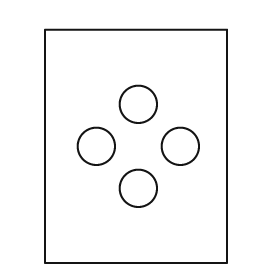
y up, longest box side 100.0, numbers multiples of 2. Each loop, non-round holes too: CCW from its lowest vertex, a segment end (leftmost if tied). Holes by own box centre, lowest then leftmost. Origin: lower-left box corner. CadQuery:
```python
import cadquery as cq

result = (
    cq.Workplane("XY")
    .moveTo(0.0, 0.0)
    .lineTo(78.0, 0.0)
    .lineTo(78.0, 100.0)
    .lineTo(0.0, 100.0)
    .close()
    .moveTo(40.0, 32.0)
    .circle(8.0)
    .moveTo(22.0, 50.0)
    .circle(8.0)
    .moveTo(58.0, 50.0)
    .circle(8.0)
    .moveTo(40.0, 68.0)
    .circle(8.0)
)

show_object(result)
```